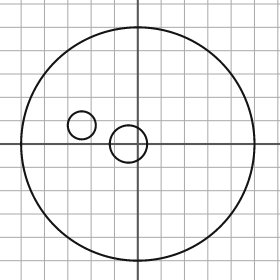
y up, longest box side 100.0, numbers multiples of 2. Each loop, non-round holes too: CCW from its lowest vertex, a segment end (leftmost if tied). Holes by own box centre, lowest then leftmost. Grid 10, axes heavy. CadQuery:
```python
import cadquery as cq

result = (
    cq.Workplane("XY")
    .moveTo(0.0, 0.0)
    .circle(50.0)
    .moveTo(-4.0, 0.0)
    .circle(8.0)
    .moveTo(-24.0, 8.0)
    .circle(6.0)
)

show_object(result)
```